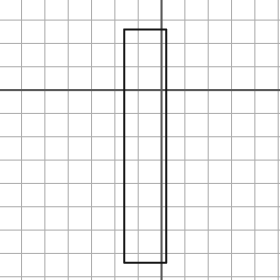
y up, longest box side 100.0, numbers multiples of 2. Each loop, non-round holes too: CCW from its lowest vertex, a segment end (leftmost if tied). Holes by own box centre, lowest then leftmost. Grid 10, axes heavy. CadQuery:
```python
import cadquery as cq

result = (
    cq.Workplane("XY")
    .moveTo(-16.0, -74.0)
    .lineTo(2.0, -74.0)
    .lineTo(2.0, 26.0)
    .lineTo(-16.0, 26.0)
    .close()
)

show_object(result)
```